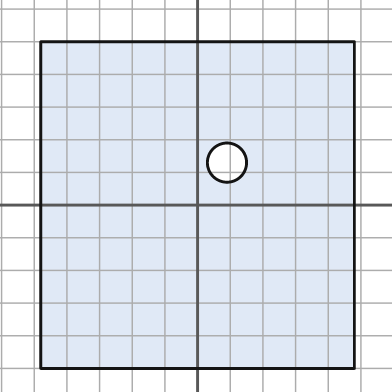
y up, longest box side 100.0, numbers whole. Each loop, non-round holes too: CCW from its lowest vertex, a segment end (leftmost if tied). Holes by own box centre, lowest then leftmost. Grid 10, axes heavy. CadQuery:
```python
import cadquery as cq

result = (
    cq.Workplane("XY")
    .moveTo(-48.0, -50.0)
    .lineTo(48.0, -50.0)
    .lineTo(48.0, 50.0)
    .lineTo(-48.0, 50.0)
    .close()
    .moveTo(9.0, 13.0)
    .circle(6.0)
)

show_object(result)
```